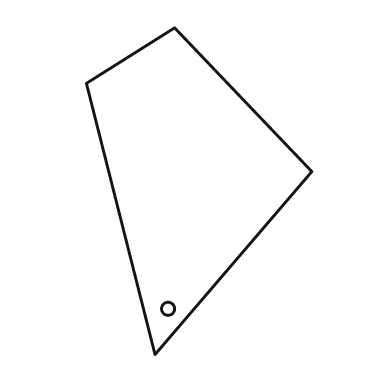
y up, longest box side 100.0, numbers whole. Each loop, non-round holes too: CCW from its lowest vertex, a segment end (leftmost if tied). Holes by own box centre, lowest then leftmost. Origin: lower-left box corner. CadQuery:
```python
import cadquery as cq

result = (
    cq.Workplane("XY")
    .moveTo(21.0, 0.0)
    .lineTo(69.0, 56.0)
    .lineTo(27.0, 100.0)
    .lineTo(0.0, 83.0)
    .close()
    .moveTo(25.0, 14.0)
    .circle(2.0)
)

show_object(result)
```